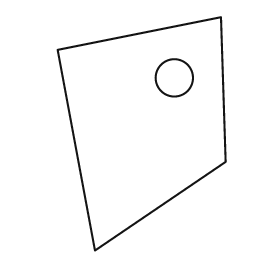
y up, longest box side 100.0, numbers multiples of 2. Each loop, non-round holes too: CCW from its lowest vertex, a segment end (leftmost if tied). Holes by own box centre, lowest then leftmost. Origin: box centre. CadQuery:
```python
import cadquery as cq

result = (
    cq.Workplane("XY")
    .moveTo(-20.0, -50.0)
    .lineTo(36.0, -12.0)
    .lineTo(34.0, 50.0)
    .lineTo(-36.0, 36.0)
    .close()
    .moveTo(14.0, 24.0)
    .circle(8.0)
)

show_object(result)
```